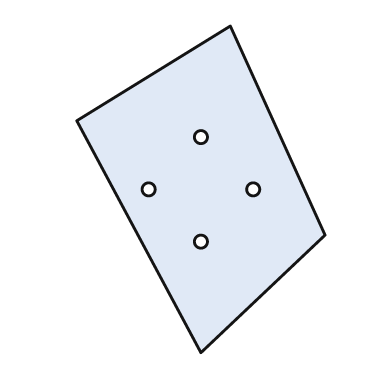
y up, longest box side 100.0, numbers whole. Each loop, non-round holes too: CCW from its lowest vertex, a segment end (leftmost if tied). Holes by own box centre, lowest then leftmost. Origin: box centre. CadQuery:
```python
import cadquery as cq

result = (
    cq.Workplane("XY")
    .moveTo(0.0, -50.0)
    .lineTo(38.0, -14.0)
    .lineTo(9.0, 50.0)
    .lineTo(-38.0, 21.0)
    .close()
    .moveTo(0.0, -16.0)
    .circle(2.0)
    .moveTo(-16.0, 0.0)
    .circle(2.0)
    .moveTo(16.0, 0.0)
    .circle(2.0)
    .moveTo(0.0, 16.0)
    .circle(2.0)
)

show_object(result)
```